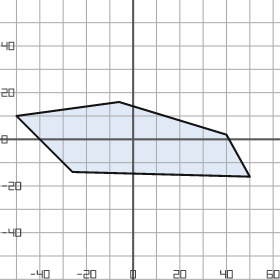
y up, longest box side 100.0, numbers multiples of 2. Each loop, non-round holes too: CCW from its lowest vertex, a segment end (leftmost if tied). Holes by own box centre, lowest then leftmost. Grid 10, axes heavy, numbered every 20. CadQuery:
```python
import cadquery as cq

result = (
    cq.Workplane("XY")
    .moveTo(50.0, -16.0)
    .lineTo(40.0, 2.0)
    .lineTo(-6.0, 16.0)
    .lineTo(-50.0, 10.0)
    .lineTo(-26.0, -14.0)
    .close()
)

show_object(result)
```